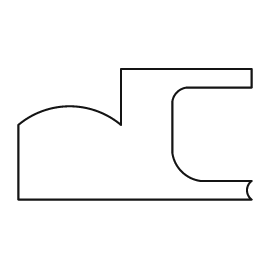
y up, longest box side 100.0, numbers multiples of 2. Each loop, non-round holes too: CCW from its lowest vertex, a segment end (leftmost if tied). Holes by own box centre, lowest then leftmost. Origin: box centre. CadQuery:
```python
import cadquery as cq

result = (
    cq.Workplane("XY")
    .moveTo(-50.0, -28.0)
    .lineTo(50.0, -28.0)
    .threePointArc((48.0, -24.0), (50.0, -20.0))
    .lineTo(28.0, -20.0)
    .threePointArc((20.0, -16.0), (16.0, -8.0))
    .lineTo(16.0, 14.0)
    .threePointArc((18.0, 18.0), (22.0, 20.0))
    .lineTo(50.0, 20.0)
    .lineTo(50.0, 28.0)
    .lineTo(-6.0, 28.0)
    .lineTo(-6.0, 4.0)
    .threePointArc((-28.0, 12.0), (-50.0, 4.0))
    .close()
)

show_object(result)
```